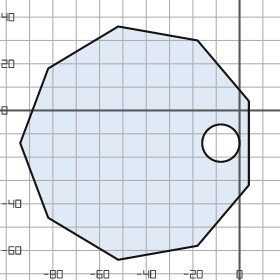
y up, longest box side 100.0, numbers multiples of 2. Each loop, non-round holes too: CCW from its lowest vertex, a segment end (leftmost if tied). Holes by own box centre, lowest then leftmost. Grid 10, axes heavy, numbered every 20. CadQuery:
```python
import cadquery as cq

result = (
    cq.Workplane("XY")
    .moveTo(-52.0, -64.0)
    .lineTo(-18.0, -58.0)
    .lineTo(4.0, -32.0)
    .lineTo(4.0, 4.0)
    .lineTo(-18.0, 30.0)
    .lineTo(-52.0, 36.0)
    .lineTo(-82.0, 18.0)
    .lineTo(-94.0, -14.0)
    .lineTo(-82.0, -46.0)
    .close()
    .moveTo(-8.0, -14.0)
    .circle(8.0)
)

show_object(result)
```